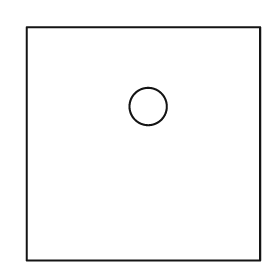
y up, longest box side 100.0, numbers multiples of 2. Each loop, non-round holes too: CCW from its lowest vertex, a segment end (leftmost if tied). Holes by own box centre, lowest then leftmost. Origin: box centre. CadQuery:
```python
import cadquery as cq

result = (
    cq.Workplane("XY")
    .moveTo(-50.0, -50.0)
    .lineTo(50.0, -50.0)
    .lineTo(50.0, 50.0)
    .lineTo(-50.0, 50.0)
    .close()
    .moveTo(2.0, 16.0)
    .circle(8.0)
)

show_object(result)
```